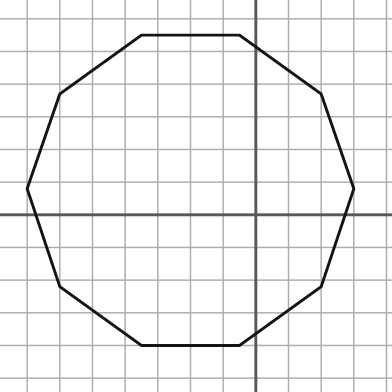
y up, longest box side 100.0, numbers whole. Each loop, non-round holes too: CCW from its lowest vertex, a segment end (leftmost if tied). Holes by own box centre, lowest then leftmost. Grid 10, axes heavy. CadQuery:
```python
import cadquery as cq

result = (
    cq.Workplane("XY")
    .moveTo(-35.0, -40.0)
    .lineTo(-5.0, -40.0)
    .lineTo(20.0, -22.0)
    .lineTo(30.0, 8.0)
    .lineTo(20.0, 37.0)
    .lineTo(-5.0, 55.0)
    .lineTo(-35.0, 55.0)
    .lineTo(-60.0, 37.0)
    .lineTo(-70.0, 8.0)
    .lineTo(-60.0, -22.0)
    .close()
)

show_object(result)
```